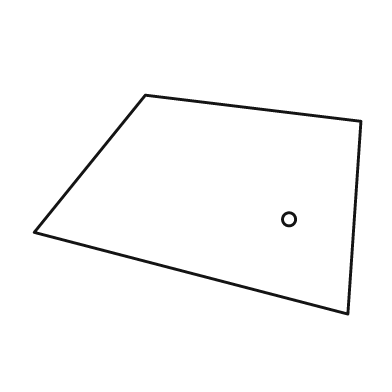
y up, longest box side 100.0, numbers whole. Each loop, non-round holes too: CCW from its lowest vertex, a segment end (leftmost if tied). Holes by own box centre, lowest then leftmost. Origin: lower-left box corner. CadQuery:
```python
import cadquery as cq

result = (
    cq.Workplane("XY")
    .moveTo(96.0, 0.0)
    .lineTo(100.0, 59.0)
    .lineTo(34.0, 67.0)
    .lineTo(0.0, 25.0)
    .close()
    .moveTo(78.0, 29.0)
    .circle(2.0)
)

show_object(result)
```